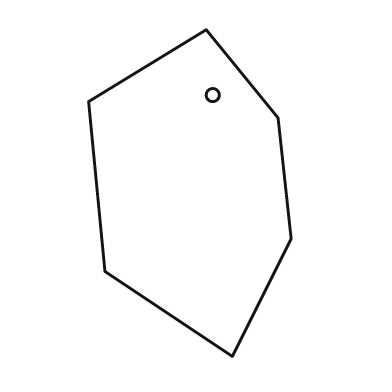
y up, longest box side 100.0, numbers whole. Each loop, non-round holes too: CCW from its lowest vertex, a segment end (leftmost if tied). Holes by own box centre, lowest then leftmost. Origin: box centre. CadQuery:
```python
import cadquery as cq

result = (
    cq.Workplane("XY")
    .moveTo(13.0, -50.0)
    .lineTo(31.0, -14.0)
    .lineTo(27.0, 23.0)
    .lineTo(5.0, 50.0)
    .lineTo(-31.0, 28.0)
    .lineTo(-26.0, -24.0)
    .close()
    .moveTo(7.0, 30.0)
    .circle(2.0)
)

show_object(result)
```